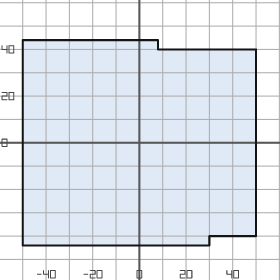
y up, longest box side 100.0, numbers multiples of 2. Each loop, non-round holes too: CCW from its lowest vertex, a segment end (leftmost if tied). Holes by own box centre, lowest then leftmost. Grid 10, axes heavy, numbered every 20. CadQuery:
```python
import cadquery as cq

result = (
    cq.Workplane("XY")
    .moveTo(-50.0, -44.0)
    .lineTo(30.0, -44.0)
    .lineTo(30.0, -40.0)
    .lineTo(50.0, -40.0)
    .lineTo(50.0, 40.0)
    .lineTo(8.0, 40.0)
    .lineTo(8.0, 44.0)
    .lineTo(-50.0, 44.0)
    .close()
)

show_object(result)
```